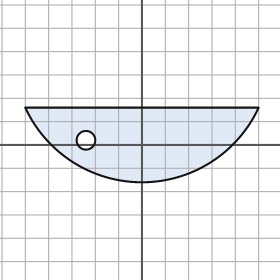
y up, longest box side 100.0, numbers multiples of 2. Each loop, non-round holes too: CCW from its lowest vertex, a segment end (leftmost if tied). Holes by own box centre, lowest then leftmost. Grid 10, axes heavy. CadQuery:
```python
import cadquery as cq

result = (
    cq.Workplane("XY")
    .moveTo(-50.0, 16.0)
    .threePointArc((0.0, -16.0), (50.0, 16.0))
    .close()
    .moveTo(-24.0, 2.0)
    .circle(4.0)
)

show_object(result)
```